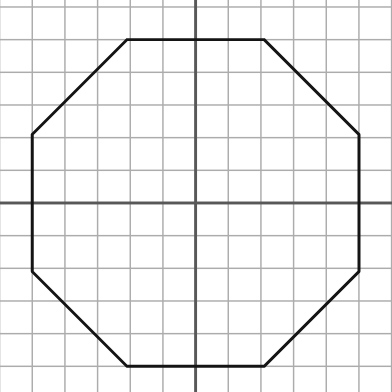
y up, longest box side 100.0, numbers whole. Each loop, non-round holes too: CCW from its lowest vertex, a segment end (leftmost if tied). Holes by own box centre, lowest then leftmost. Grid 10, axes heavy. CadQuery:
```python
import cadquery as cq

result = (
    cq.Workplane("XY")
    .moveTo(-21.0, -50.0)
    .lineTo(21.0, -50.0)
    .lineTo(50.0, -21.0)
    .lineTo(50.0, 21.0)
    .lineTo(21.0, 50.0)
    .lineTo(-21.0, 50.0)
    .lineTo(-50.0, 21.0)
    .lineTo(-50.0, -21.0)
    .close()
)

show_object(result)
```